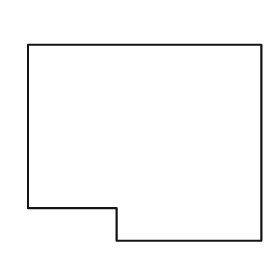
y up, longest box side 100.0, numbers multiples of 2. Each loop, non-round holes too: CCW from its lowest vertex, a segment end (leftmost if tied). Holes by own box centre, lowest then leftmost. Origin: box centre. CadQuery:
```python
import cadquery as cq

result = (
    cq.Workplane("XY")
    .moveTo(-12.0, -42.0)
    .lineTo(50.0, -42.0)
    .lineTo(50.0, 42.0)
    .lineTo(-50.0, 42.0)
    .lineTo(-50.0, -28.0)
    .lineTo(-12.0, -28.0)
    .close()
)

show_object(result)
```